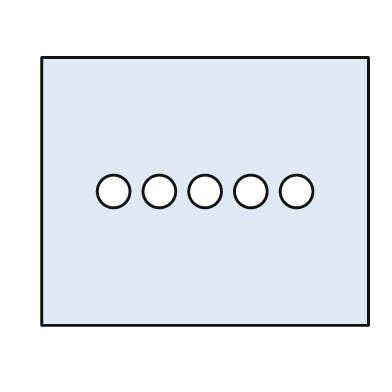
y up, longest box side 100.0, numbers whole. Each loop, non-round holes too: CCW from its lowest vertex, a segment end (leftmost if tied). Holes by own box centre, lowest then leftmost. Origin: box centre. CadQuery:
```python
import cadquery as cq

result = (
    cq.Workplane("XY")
    .moveTo(-50.0, -41.0)
    .lineTo(50.0, -41.0)
    .lineTo(50.0, 41.0)
    .lineTo(-50.0, 41.0)
    .close()
    .moveTo(-28.0, 0.0)
    .circle(5.0)
    .moveTo(-14.0, 0.0)
    .circle(5.0)
    .moveTo(0.0, 0.0)
    .circle(5.0)
    .moveTo(14.0, 0.0)
    .circle(5.0)
    .moveTo(28.0, 0.0)
    .circle(5.0)
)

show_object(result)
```